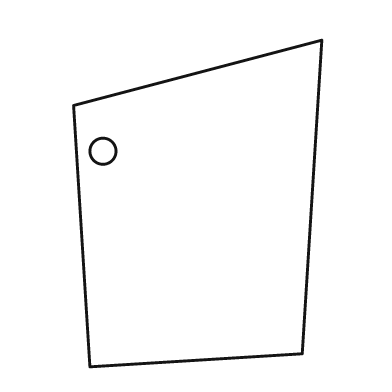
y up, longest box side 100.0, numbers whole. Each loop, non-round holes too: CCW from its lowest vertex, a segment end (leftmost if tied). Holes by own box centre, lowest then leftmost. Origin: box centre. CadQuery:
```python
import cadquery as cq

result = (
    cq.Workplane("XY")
    .moveTo(-33.0, -50.0)
    .lineTo(32.0, -46.0)
    .lineTo(38.0, 50.0)
    .lineTo(-38.0, 30.0)
    .close()
    .moveTo(-29.0, 16.0)
    .circle(4.0)
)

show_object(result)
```